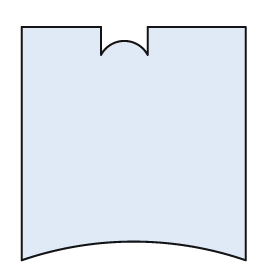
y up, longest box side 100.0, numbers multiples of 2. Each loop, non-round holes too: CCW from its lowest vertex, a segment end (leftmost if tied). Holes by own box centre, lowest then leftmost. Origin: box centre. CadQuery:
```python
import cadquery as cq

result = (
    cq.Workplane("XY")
    .moveTo(-48.0, -50.0)
    .threePointArc((0.0, -42.0), (48.0, -50.0))
    .lineTo(48.0, 50.0)
    .lineTo(6.0, 50.0)
    .lineTo(6.0, 38.0)
    .threePointArc((-4.0, 44.0), (-14.0, 38.0))
    .lineTo(-14.0, 50.0)
    .lineTo(-48.0, 50.0)
    .close()
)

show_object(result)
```